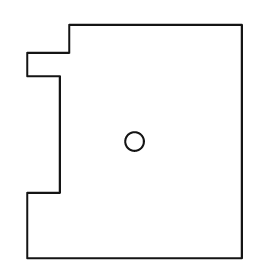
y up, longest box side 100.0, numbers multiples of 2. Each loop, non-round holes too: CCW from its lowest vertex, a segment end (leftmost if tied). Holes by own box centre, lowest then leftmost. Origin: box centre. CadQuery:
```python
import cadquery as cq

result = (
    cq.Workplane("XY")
    .moveTo(-46.0, -50.0)
    .lineTo(46.0, -50.0)
    .lineTo(46.0, 50.0)
    .lineTo(-28.0, 50.0)
    .lineTo(-28.0, 38.0)
    .lineTo(-46.0, 38.0)
    .lineTo(-46.0, 28.0)
    .lineTo(-32.0, 28.0)
    .lineTo(-32.0, -22.0)
    .lineTo(-46.0, -22.0)
    .close()
    .moveTo(0.0, 0.0)
    .circle(4.0)
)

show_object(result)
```